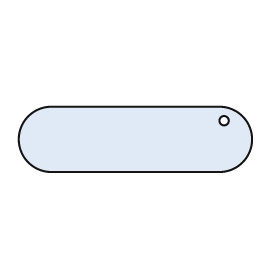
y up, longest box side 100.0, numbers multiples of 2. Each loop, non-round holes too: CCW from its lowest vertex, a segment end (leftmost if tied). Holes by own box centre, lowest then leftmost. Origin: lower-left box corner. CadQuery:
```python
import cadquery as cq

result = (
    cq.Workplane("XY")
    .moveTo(14.0, 0.0)
    .lineTo(86.0, 0.0)
    .threePointArc((100.0, 14.0), (86.0, 28.0))
    .lineTo(14.0, 28.0)
    .threePointArc((0.0, 14.0), (14.0, 0.0))
    .close()
    .moveTo(88.0, 22.0)
    .circle(2.0)
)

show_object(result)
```